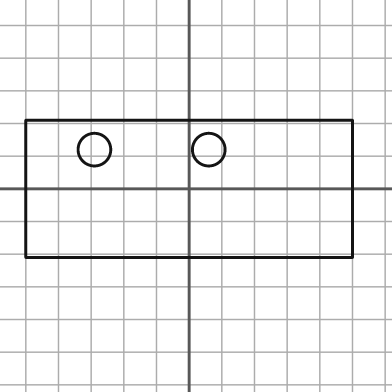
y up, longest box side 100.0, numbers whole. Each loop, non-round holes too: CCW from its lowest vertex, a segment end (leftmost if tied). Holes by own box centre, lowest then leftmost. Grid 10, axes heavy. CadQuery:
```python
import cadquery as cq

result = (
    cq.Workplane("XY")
    .moveTo(-50.0, -21.0)
    .lineTo(50.0, -21.0)
    .lineTo(50.0, 21.0)
    .lineTo(-50.0, 21.0)
    .close()
    .moveTo(-29.0, 12.0)
    .circle(5.0)
    .moveTo(6.0, 12.0)
    .circle(5.0)
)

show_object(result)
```